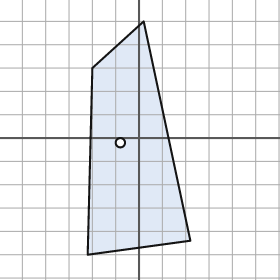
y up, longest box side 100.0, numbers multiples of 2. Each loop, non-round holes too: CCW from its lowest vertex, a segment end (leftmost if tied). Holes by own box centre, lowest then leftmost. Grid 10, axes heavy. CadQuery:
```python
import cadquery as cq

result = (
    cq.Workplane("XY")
    .moveTo(-22.0, -50.0)
    .lineTo(22.0, -44.0)
    .lineTo(2.0, 50.0)
    .lineTo(-20.0, 30.0)
    .close()
    .moveTo(-8.0, -2.0)
    .circle(2.0)
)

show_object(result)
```